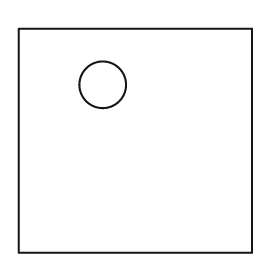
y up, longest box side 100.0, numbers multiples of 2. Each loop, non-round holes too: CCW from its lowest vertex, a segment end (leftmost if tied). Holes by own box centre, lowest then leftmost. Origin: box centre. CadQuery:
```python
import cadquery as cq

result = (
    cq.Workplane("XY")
    .moveTo(-50.0, -48.0)
    .lineTo(50.0, -48.0)
    .lineTo(50.0, 48.0)
    .lineTo(-50.0, 48.0)
    .close()
    .moveTo(-14.0, 24.0)
    .circle(10.0)
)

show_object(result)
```